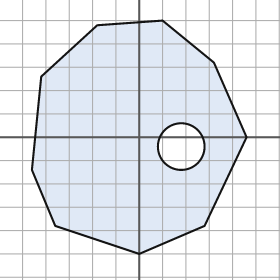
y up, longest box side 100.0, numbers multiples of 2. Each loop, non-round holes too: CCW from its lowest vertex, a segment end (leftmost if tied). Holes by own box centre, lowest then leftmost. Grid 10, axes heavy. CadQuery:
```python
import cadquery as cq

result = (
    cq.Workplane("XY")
    .moveTo(0.0, -50.0)
    .lineTo(28.0, -38.0)
    .lineTo(46.0, 0.0)
    .lineTo(32.0, 32.0)
    .lineTo(10.0, 50.0)
    .lineTo(-18.0, 48.0)
    .lineTo(-42.0, 26.0)
    .lineTo(-46.0, -14.0)
    .lineTo(-36.0, -38.0)
    .close()
    .moveTo(18.0, -4.0)
    .circle(10.0)
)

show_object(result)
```